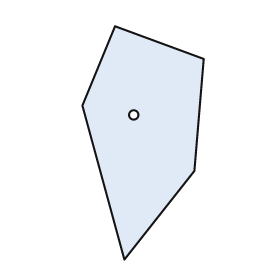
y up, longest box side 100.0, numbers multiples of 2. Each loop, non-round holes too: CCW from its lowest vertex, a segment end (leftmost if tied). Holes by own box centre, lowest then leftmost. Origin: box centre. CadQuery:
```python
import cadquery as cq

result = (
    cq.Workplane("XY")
    .moveTo(-8.0, -50.0)
    .lineTo(22.0, -12.0)
    .lineTo(26.0, 36.0)
    .lineTo(-12.0, 50.0)
    .lineTo(-26.0, 16.0)
    .close()
    .moveTo(-4.0, 12.0)
    .circle(2.0)
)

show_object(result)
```